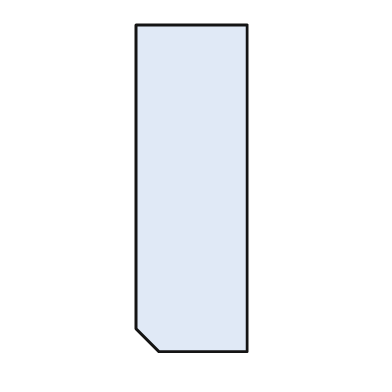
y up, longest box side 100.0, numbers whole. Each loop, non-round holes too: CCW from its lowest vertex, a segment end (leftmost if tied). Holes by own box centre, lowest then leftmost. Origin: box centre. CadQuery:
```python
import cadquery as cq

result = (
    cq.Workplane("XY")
    .moveTo(-10.0, -50.0)
    .lineTo(17.0, -50.0)
    .lineTo(17.0, 50.0)
    .lineTo(-17.0, 50.0)
    .lineTo(-17.0, -43.0)
    .close()
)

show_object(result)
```